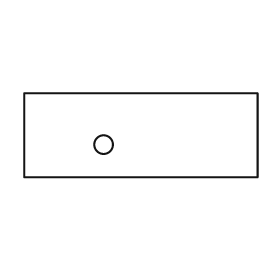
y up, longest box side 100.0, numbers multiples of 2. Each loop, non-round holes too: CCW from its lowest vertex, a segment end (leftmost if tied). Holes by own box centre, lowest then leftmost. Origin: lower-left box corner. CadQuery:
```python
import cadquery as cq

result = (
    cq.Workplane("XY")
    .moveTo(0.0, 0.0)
    .lineTo(100.0, 0.0)
    .lineTo(100.0, 36.0)
    .lineTo(0.0, 36.0)
    .close()
    .moveTo(34.0, 14.0)
    .circle(4.0)
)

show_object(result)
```